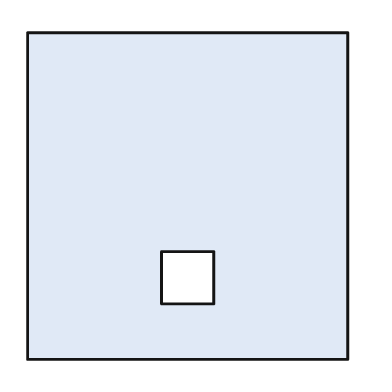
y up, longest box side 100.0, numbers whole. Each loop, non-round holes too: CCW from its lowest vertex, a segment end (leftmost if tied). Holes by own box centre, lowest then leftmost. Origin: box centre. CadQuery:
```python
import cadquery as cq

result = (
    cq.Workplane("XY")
    .moveTo(-49.0, -50.0)
    .lineTo(49.0, -50.0)
    .lineTo(49.0, 50.0)
    .lineTo(-49.0, 50.0)
    .close()
    .moveTo(-8.0, -33.0)
    .lineTo(8.0, -33.0)
    .lineTo(8.0, -17.0)
    .lineTo(-8.0, -17.0)
    .close()
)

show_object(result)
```